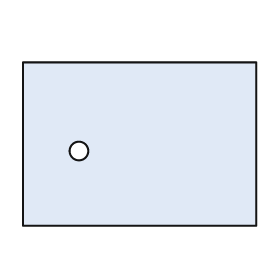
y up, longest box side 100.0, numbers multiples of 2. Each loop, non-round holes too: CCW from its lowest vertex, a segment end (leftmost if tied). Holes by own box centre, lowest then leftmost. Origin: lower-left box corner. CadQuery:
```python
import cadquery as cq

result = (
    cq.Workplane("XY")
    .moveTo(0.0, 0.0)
    .lineTo(100.0, 0.0)
    .lineTo(100.0, 70.0)
    .lineTo(0.0, 70.0)
    .close()
    .moveTo(24.0, 32.0)
    .circle(4.0)
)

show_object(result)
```